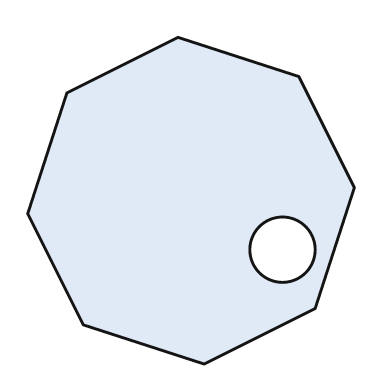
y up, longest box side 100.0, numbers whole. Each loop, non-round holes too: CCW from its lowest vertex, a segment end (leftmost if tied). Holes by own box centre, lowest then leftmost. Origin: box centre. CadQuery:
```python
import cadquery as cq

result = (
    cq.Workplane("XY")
    .moveTo(4.0, -50.0)
    .lineTo(38.0, -33.0)
    .lineTo(50.0, 4.0)
    .lineTo(33.0, 38.0)
    .lineTo(-4.0, 50.0)
    .lineTo(-38.0, 33.0)
    .lineTo(-50.0, -4.0)
    .lineTo(-33.0, -38.0)
    .close()
    .moveTo(28.0, -15.0)
    .circle(10.0)
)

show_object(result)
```